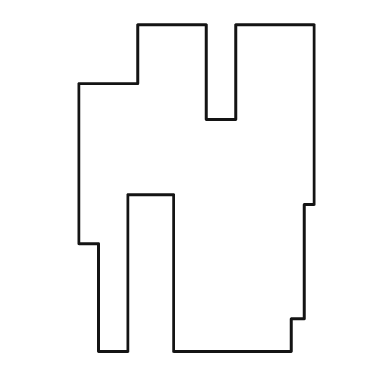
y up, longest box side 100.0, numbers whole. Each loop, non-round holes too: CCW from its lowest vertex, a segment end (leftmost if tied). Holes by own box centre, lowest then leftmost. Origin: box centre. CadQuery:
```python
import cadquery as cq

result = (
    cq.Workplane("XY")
    .moveTo(-30.0, -50.0)
    .lineTo(-21.0, -50.0)
    .lineTo(-21.0, -2.0)
    .lineTo(-7.0, -2.0)
    .lineTo(-7.0, -50.0)
    .lineTo(29.0, -50.0)
    .lineTo(29.0, -40.0)
    .lineTo(33.0, -40.0)
    .lineTo(33.0, -5.0)
    .lineTo(36.0, -5.0)
    .lineTo(36.0, 50.0)
    .lineTo(12.0, 50.0)
    .lineTo(12.0, 21.0)
    .lineTo(3.0, 21.0)
    .lineTo(3.0, 50.0)
    .lineTo(-18.0, 50.0)
    .lineTo(-18.0, 32.0)
    .lineTo(-36.0, 32.0)
    .lineTo(-36.0, -17.0)
    .lineTo(-30.0, -17.0)
    .close()
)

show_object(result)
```